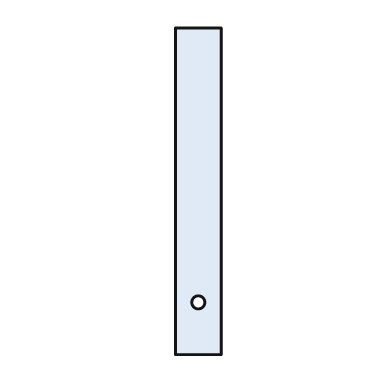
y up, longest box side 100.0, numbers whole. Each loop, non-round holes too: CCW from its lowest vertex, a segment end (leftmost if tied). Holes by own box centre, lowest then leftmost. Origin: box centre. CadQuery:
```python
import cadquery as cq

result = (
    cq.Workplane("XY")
    .moveTo(-7.0, -50.0)
    .lineTo(7.0, -50.0)
    .lineTo(7.0, 50.0)
    .lineTo(-7.0, 50.0)
    .close()
    .moveTo(0.0, -34.0)
    .circle(2.0)
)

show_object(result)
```